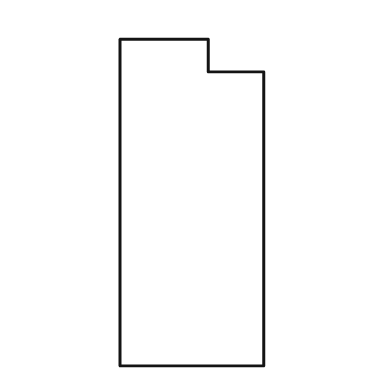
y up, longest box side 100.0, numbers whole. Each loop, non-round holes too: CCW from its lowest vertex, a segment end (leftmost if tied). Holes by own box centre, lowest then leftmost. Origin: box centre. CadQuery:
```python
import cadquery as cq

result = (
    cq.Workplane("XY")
    .moveTo(-22.0, -50.0)
    .lineTo(22.0, -50.0)
    .lineTo(22.0, 40.0)
    .lineTo(5.0, 40.0)
    .lineTo(5.0, 50.0)
    .lineTo(-22.0, 50.0)
    .close()
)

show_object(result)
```